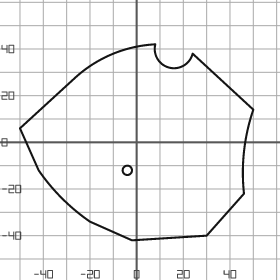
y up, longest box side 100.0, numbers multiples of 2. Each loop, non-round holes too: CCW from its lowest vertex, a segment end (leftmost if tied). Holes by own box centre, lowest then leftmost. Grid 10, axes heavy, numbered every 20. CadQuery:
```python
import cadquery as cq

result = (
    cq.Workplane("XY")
    .moveTo(-2.0, -42.0)
    .lineTo(30.0, -40.0)
    .lineTo(46.0, -22.0)
    .threePointArc((46.0, -4.0), (50.0, 14.0))
    .lineTo(24.0, 38.0)
    .threePointArc((14.0, 32.0), (8.0, 42.0))
    .threePointArc((-10.0, 38.0), (-26.0, 28.0))
    .lineTo(-50.0, 6.0)
    .lineTo(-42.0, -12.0)
    .threePointArc((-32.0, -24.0), (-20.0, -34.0))
    .close()
    .moveTo(-4.0, -12.0)
    .circle(2.0)
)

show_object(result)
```